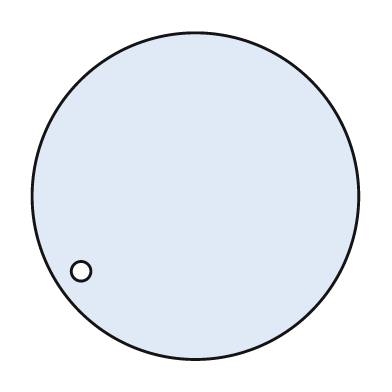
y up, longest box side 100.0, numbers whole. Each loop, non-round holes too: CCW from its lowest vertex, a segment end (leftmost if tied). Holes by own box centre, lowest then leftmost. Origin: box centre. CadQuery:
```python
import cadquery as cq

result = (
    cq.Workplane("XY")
    .moveTo(0.0, 0.0)
    .circle(50.0)
    .moveTo(-35.0, -23.0)
    .circle(3.0)
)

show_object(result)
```